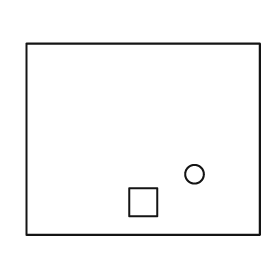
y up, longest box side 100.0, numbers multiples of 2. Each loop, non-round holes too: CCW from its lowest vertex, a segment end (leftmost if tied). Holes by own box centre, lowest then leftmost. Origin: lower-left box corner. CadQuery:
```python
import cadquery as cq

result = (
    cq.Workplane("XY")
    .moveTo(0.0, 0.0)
    .lineTo(100.0, 0.0)
    .lineTo(100.0, 82.0)
    .lineTo(0.0, 82.0)
    .close()
    .moveTo(44.0, 8.0)
    .lineTo(56.0, 8.0)
    .lineTo(56.0, 20.0)
    .lineTo(44.0, 20.0)
    .close()
    .moveTo(72.0, 26.0)
    .circle(4.0)
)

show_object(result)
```